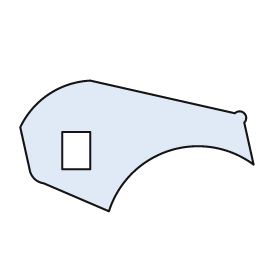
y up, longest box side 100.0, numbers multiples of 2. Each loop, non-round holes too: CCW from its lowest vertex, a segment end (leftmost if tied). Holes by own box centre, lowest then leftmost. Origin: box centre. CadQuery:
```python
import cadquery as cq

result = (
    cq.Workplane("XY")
    .moveTo(-12.0, -28.0)
    .threePointArc((14.0, -2.0), (50.0, -8.0))
    .lineTo(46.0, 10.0)
    .threePointArc((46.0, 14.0), (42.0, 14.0))
    .lineTo(-20.0, 28.0)
    .threePointArc((-38.0, 22.0), (-50.0, 8.0))
    .lineTo(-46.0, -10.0)
    .threePointArc((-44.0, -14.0), (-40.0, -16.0))
    .close()
    .moveTo(-32.0, -10.0)
    .lineTo(-20.0, -10.0)
    .lineTo(-20.0, 6.0)
    .lineTo(-32.0, 6.0)
    .close()
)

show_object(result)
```